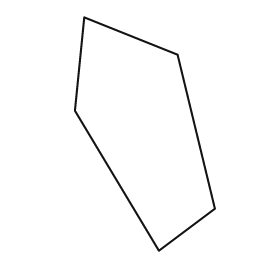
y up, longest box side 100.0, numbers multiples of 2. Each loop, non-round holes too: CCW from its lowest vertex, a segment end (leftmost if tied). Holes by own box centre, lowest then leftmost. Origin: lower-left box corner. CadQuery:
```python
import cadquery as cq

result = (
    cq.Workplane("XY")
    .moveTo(36.0, 0.0)
    .lineTo(60.0, 18.0)
    .lineTo(44.0, 84.0)
    .lineTo(4.0, 100.0)
    .lineTo(0.0, 60.0)
    .close()
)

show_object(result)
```